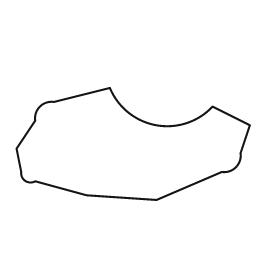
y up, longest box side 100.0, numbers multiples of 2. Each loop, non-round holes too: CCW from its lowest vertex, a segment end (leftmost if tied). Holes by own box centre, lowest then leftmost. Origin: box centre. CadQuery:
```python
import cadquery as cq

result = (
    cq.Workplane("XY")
    .moveTo(10.0, -24.0)
    .lineTo(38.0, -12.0)
    .threePointArc((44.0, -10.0), (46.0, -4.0))
    .lineTo(50.0, 8.0)
    .lineTo(34.0, 16.0)
    .threePointArc((10.0, 8.0), (-10.0, 24.0))
    .lineTo(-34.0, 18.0)
    .threePointArc((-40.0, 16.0), (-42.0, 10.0))
    .lineTo(-50.0, -2.0)
    .lineTo(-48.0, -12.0)
    .threePointArc((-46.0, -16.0), (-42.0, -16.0))
    .lineTo(-20.0, -22.0)
    .close()
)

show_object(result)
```